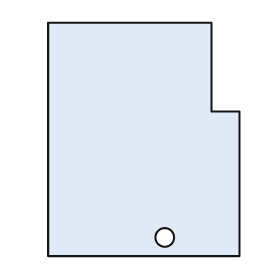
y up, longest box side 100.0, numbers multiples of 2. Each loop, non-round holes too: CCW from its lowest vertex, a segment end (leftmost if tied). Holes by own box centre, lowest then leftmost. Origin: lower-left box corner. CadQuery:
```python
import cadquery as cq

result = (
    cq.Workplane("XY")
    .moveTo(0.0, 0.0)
    .lineTo(82.0, 0.0)
    .lineTo(82.0, 62.0)
    .lineTo(70.0, 62.0)
    .lineTo(70.0, 100.0)
    .lineTo(0.0, 100.0)
    .close()
    .moveTo(50.0, 8.0)
    .circle(4.0)
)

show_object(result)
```